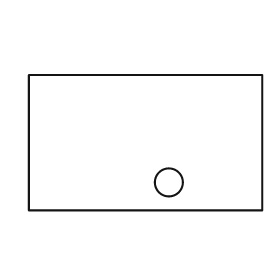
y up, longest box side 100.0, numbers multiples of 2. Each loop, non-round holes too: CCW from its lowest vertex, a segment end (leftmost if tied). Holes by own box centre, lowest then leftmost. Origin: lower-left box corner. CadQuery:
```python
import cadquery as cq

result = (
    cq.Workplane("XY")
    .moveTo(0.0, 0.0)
    .lineTo(100.0, 0.0)
    .lineTo(100.0, 58.0)
    .lineTo(0.0, 58.0)
    .close()
    .moveTo(60.0, 12.0)
    .circle(6.0)
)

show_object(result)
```